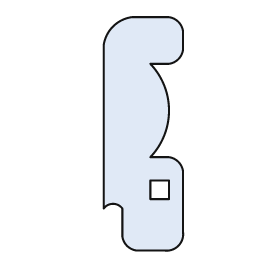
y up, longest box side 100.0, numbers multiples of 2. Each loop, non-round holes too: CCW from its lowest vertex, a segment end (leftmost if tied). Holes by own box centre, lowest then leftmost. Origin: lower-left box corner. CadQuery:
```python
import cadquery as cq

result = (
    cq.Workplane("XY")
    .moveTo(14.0, 0.0)
    .lineTo(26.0, 0.0)
    .threePointArc((32.0, 2.0), (34.0, 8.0))
    .lineTo(34.0, 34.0)
    .threePointArc((32.0, 38.0), (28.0, 40.0))
    .lineTo(20.0, 40.0)
    .threePointArc((28.0, 60.0), (20.0, 80.0))
    .lineTo(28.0, 80.0)
    .threePointArc((32.0, 82.0), (34.0, 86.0))
    .lineTo(34.0, 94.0)
    .threePointArc((32.0, 98.0), (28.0, 100.0))
    .lineTo(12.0, 100.0)
    .threePointArc((4.0, 96.0), (0.0, 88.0))
    .lineTo(0.0, 18.0)
    .threePointArc((4.0, 20.0), (8.0, 18.0))
    .lineTo(8.0, 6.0)
    .threePointArc((10.0, 2.0), (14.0, 0.0))
    .close()
    .moveTo(20.0, 22.0)
    .lineTo(28.0, 22.0)
    .lineTo(28.0, 30.0)
    .lineTo(20.0, 30.0)
    .close()
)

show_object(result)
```